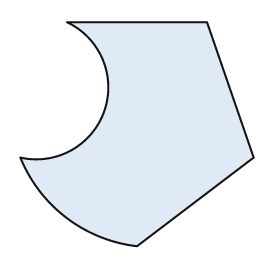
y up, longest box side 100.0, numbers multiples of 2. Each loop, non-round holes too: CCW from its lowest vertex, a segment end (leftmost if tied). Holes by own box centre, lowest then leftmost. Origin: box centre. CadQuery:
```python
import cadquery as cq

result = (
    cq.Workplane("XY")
    .moveTo(0.0, -48.0)
    .lineTo(50.0, -10.0)
    .lineTo(30.0, 48.0)
    .lineTo(-30.0, 48.0)
    .threePointArc((-14.0, 10.0), (-50.0, -10.0))
    .threePointArc((-30.0, -36.0), (0.0, -48.0))
    .close()
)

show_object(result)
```